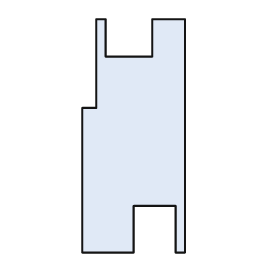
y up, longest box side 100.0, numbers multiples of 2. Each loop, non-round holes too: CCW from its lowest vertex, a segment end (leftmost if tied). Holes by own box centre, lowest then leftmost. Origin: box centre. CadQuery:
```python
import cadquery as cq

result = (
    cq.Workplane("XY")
    .moveTo(-22.0, -50.0)
    .lineTo(0.0, -50.0)
    .lineTo(0.0, -30.0)
    .lineTo(18.0, -30.0)
    .lineTo(18.0, -50.0)
    .lineTo(22.0, -50.0)
    .lineTo(22.0, 50.0)
    .lineTo(8.0, 50.0)
    .lineTo(8.0, 34.0)
    .lineTo(-12.0, 34.0)
    .lineTo(-12.0, 50.0)
    .lineTo(-16.0, 50.0)
    .lineTo(-16.0, 12.0)
    .lineTo(-22.0, 12.0)
    .close()
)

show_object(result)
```